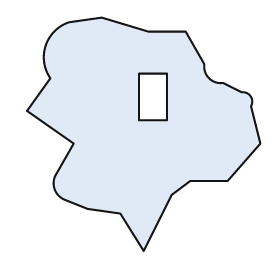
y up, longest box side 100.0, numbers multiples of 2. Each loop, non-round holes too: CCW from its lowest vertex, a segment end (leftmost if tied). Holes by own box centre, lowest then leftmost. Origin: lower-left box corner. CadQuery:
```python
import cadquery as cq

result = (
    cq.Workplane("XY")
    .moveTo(50.0, 0.0)
    .lineTo(62.0, 24.0)
    .lineTo(70.0, 30.0)
    .lineTo(86.0, 30.0)
    .lineTo(100.0, 46.0)
    .lineTo(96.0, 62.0)
    .threePointArc((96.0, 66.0), (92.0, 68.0))
    .lineTo(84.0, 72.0)
    .threePointArc((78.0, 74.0), (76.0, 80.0))
    .lineTo(68.0, 94.0)
    .lineTo(52.0, 94.0)
    .lineTo(32.0, 100.0)
    .lineTo(18.0, 98.0)
    .threePointArc((8.0, 88.0), (10.0, 74.0))
    .lineTo(0.0, 60.0)
    .lineTo(20.0, 46.0)
    .lineTo(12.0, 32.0)
    .threePointArc((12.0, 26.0), (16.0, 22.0))
    .lineTo(26.0, 18.0)
    .lineTo(40.0, 16.0)
    .close()
    .moveTo(48.0, 56.0)
    .lineTo(60.0, 56.0)
    .lineTo(60.0, 76.0)
    .lineTo(48.0, 76.0)
    .close()
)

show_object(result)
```